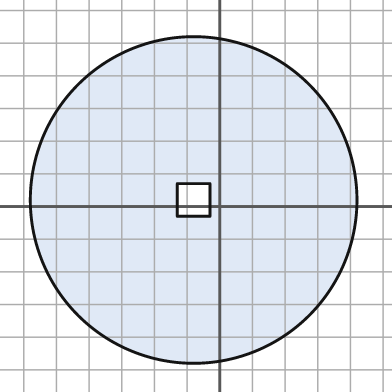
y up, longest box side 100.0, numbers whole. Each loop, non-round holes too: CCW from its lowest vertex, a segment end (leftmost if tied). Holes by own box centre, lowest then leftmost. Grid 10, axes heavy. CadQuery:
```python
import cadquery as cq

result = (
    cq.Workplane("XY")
    .moveTo(-8.0, 2.0)
    .circle(50.0)
    .moveTo(-13.0, -3.0)
    .lineTo(-3.0, -3.0)
    .lineTo(-3.0, 7.0)
    .lineTo(-13.0, 7.0)
    .close()
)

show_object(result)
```